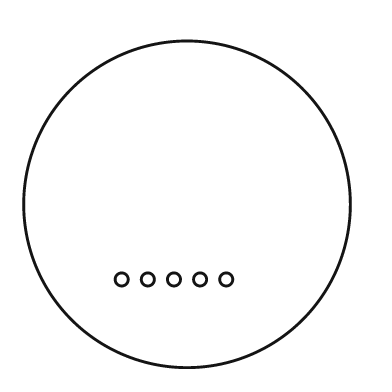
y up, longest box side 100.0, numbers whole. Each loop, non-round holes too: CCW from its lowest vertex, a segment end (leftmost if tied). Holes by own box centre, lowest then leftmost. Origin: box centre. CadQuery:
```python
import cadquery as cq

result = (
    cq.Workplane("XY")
    .moveTo(0.0, 0.0)
    .circle(50.0)
    .moveTo(-20.0, -23.0)
    .circle(2.0)
    .moveTo(-12.0, -23.0)
    .circle(2.0)
    .moveTo(-4.0, -23.0)
    .circle(2.0)
    .moveTo(4.0, -23.0)
    .circle(2.0)
    .moveTo(12.0, -23.0)
    .circle(2.0)
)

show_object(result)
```